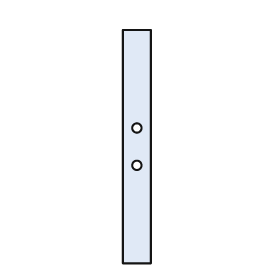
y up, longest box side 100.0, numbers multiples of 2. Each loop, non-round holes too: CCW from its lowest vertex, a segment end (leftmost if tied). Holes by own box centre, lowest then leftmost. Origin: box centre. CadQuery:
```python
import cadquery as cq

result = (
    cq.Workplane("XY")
    .moveTo(-6.0, -50.0)
    .lineTo(6.0, -50.0)
    .lineTo(6.0, 50.0)
    .lineTo(-6.0, 50.0)
    .close()
    .moveTo(0.0, -8.0)
    .circle(2.0)
    .moveTo(0.0, 8.0)
    .circle(2.0)
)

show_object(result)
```